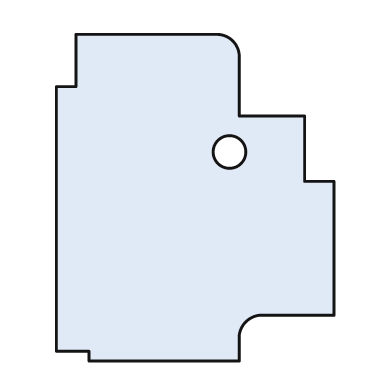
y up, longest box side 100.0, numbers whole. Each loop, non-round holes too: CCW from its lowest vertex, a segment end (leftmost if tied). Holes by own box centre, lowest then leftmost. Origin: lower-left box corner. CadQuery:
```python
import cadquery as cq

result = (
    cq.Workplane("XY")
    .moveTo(10.0, 0.0)
    .lineTo(56.0, 0.0)
    .lineTo(56.0, 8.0)
    .threePointArc((58.0, 12.0), (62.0, 14.0))
    .lineTo(85.0, 14.0)
    .lineTo(85.0, 55.0)
    .lineTo(76.0, 55.0)
    .lineTo(76.0, 75.0)
    .lineTo(56.0, 75.0)
    .lineTo(56.0, 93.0)
    .threePointArc((54.0, 98.0), (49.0, 100.0))
    .lineTo(6.0, 100.0)
    .lineTo(6.0, 84.0)
    .lineTo(0.0, 84.0)
    .lineTo(0.0, 3.0)
    .lineTo(10.0, 3.0)
    .close()
    .moveTo(53.0, 64.0)
    .circle(5.0)
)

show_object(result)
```